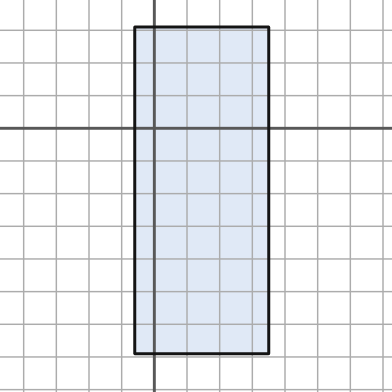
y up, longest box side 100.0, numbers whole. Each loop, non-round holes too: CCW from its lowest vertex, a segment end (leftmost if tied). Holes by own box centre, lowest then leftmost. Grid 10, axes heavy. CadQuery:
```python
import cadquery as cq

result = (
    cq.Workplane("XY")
    .moveTo(-6.0, -69.0)
    .lineTo(35.0, -69.0)
    .lineTo(35.0, 31.0)
    .lineTo(-6.0, 31.0)
    .close()
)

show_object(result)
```